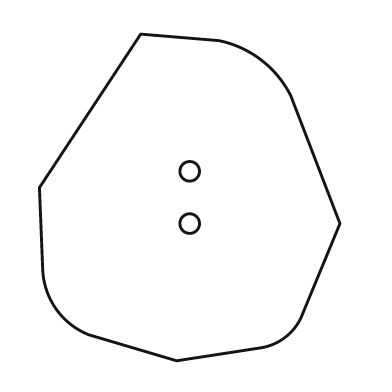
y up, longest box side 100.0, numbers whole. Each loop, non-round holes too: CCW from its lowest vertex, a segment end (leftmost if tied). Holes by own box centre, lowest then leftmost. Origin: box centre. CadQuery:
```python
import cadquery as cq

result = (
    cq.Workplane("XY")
    .moveTo(-4.0, -50.0)
    .lineTo(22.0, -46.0)
    .threePointArc((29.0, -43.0), (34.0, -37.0))
    .lineTo(46.0, -8.0)
    .lineTo(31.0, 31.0)
    .threePointArc((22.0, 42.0), (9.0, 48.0))
    .lineTo(-15.0, 50.0)
    .lineTo(-46.0, 3.0)
    .lineTo(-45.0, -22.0)
    .threePointArc((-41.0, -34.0), (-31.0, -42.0))
    .close()
    .moveTo(0.0, -8.0)
    .circle(3.0)
    .moveTo(0.0, 8.0)
    .circle(3.0)
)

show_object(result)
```